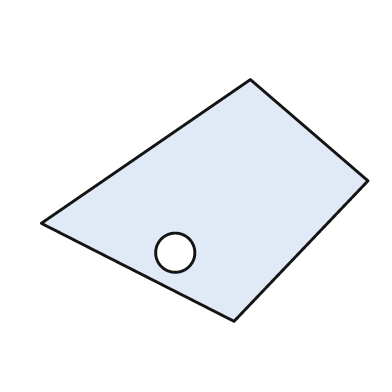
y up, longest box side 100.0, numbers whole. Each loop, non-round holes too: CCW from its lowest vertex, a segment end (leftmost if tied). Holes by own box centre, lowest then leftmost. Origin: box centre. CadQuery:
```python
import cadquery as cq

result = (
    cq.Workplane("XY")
    .moveTo(9.0, -37.0)
    .lineTo(50.0, 6.0)
    .lineTo(14.0, 37.0)
    .lineTo(-50.0, -7.0)
    .close()
    .moveTo(-9.0, -16.0)
    .circle(6.0)
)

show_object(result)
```